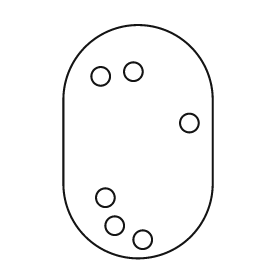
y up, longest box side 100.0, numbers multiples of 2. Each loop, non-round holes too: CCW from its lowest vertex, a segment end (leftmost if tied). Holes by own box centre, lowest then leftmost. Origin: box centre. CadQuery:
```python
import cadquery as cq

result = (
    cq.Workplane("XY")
    .moveTo(-32.0, -18.0)
    .threePointArc((0.0, -50.0), (32.0, -18.0))
    .lineTo(32.0, 18.0)
    .threePointArc((0.0, 50.0), (-32.0, 18.0))
    .close()
    .moveTo(2.0, -42.0)
    .circle(4.0)
    .moveTo(-10.0, -36.0)
    .circle(4.0)
    .moveTo(-14.0, -24.0)
    .circle(4.0)
    .moveTo(22.0, 8.0)
    .circle(4.0)
    .moveTo(-16.0, 28.0)
    .circle(4.0)
    .moveTo(-2.0, 30.0)
    .circle(4.0)
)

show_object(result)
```